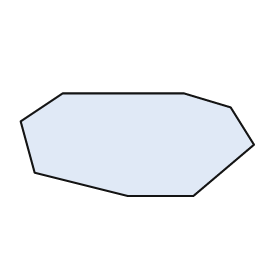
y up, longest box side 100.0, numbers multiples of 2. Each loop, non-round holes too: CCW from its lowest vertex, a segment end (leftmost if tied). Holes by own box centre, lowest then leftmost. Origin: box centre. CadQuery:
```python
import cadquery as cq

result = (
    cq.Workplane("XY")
    .moveTo(-4.0, -22.0)
    .lineTo(24.0, -22.0)
    .lineTo(50.0, 0.0)
    .lineTo(40.0, 16.0)
    .lineTo(20.0, 22.0)
    .lineTo(-32.0, 22.0)
    .lineTo(-50.0, 10.0)
    .lineTo(-44.0, -12.0)
    .close()
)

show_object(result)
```